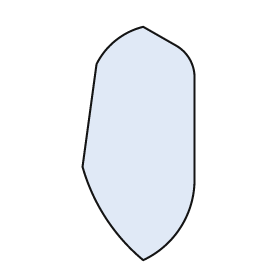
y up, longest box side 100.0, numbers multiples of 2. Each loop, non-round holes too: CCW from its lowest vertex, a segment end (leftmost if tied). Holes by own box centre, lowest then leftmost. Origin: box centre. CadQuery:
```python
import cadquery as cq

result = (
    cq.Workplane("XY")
    .moveTo(2.0, -50.0)
    .threePointArc((18.0, -36.0), (24.0, -16.0))
    .lineTo(24.0, 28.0)
    .threePointArc((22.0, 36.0), (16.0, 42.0))
    .lineTo(2.0, 50.0)
    .threePointArc((-10.0, 44.0), (-18.0, 34.0))
    .lineTo(-24.0, -10.0)
    .threePointArc((-14.0, -32.0), (2.0, -50.0))
    .close()
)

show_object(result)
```